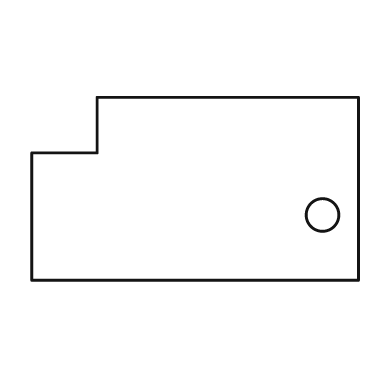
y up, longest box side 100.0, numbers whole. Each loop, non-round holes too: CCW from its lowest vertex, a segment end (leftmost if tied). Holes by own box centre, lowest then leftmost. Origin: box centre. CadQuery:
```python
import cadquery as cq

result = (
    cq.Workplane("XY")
    .moveTo(-50.0, -28.0)
    .lineTo(50.0, -28.0)
    .lineTo(50.0, 28.0)
    .lineTo(-30.0, 28.0)
    .lineTo(-30.0, 11.0)
    .lineTo(-50.0, 11.0)
    .close()
    .moveTo(39.0, -8.0)
    .circle(5.0)
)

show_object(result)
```